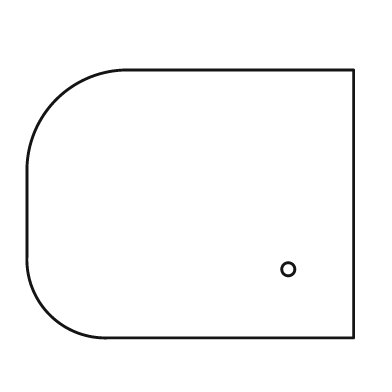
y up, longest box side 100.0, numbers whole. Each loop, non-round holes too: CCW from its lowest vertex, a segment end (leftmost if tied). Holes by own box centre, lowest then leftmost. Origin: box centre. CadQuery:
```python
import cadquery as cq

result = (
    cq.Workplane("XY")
    .moveTo(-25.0, -41.0)
    .lineTo(50.0, -41.0)
    .lineTo(50.0, 41.0)
    .lineTo(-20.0, 41.0)
    .threePointArc((-41.0, 32.0), (-50.0, 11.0))
    .lineTo(-50.0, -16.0)
    .threePointArc((-43.0, -34.0), (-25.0, -41.0))
    .close()
    .moveTo(30.0, -20.0)
    .circle(2.0)
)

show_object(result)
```